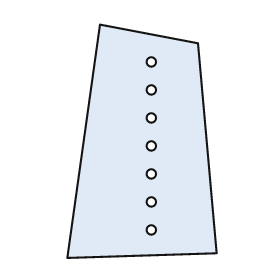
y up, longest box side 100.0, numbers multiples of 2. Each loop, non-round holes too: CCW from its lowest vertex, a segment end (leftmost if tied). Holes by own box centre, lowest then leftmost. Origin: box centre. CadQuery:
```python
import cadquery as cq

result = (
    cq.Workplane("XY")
    .moveTo(-32.0, -50.0)
    .lineTo(32.0, -48.0)
    .lineTo(24.0, 42.0)
    .lineTo(-18.0, 50.0)
    .close()
    .moveTo(4.0, -38.0)
    .circle(2.0)
    .moveTo(4.0, -26.0)
    .circle(2.0)
    .moveTo(4.0, -14.0)
    .circle(2.0)
    .moveTo(4.0, -2.0)
    .circle(2.0)
    .moveTo(4.0, 10.0)
    .circle(2.0)
    .moveTo(4.0, 22.0)
    .circle(2.0)
    .moveTo(4.0, 34.0)
    .circle(2.0)
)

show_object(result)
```